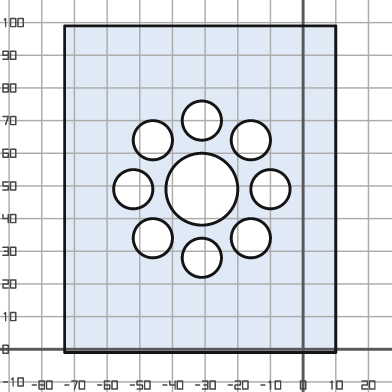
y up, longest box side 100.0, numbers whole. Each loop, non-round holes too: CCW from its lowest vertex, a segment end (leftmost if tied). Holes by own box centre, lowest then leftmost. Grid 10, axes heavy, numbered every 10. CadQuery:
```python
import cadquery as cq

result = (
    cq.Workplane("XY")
    .moveTo(-73.0, -1.0)
    .lineTo(10.0, -1.0)
    .lineTo(10.0, 99.0)
    .lineTo(-73.0, 99.0)
    .close()
    .moveTo(-31.0, 28.0)
    .circle(6.0)
    .moveTo(-46.0, 34.0)
    .circle(6.0)
    .moveTo(-16.0, 34.0)
    .circle(6.0)
    .moveTo(-52.0, 49.0)
    .circle(6.0)
    .moveTo(-31.0, 49.0)
    .circle(11.0)
    .moveTo(-10.0, 49.0)
    .circle(6.0)
    .moveTo(-46.0, 64.0)
    .circle(6.0)
    .moveTo(-16.0, 64.0)
    .circle(6.0)
    .moveTo(-31.0, 70.0)
    .circle(6.0)
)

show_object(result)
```